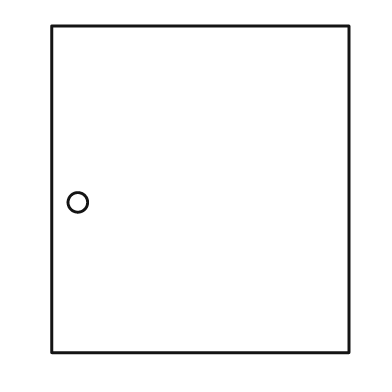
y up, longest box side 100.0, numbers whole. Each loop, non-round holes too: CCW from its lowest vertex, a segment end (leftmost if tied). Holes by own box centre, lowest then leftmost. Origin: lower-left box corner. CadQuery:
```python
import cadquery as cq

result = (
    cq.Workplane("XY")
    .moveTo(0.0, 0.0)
    .lineTo(91.0, 0.0)
    .lineTo(91.0, 100.0)
    .lineTo(0.0, 100.0)
    .close()
    .moveTo(8.0, 46.0)
    .circle(3.0)
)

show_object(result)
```